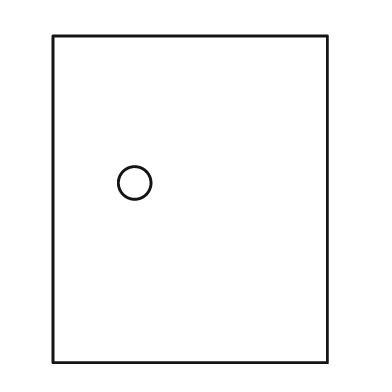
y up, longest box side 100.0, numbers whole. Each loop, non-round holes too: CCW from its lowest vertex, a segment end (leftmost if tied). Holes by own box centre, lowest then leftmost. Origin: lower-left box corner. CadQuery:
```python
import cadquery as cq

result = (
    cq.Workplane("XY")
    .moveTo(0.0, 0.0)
    .lineTo(84.0, 0.0)
    .lineTo(84.0, 100.0)
    .lineTo(0.0, 100.0)
    .close()
    .moveTo(25.0, 55.0)
    .circle(5.0)
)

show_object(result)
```